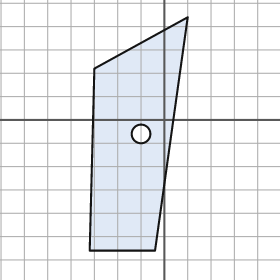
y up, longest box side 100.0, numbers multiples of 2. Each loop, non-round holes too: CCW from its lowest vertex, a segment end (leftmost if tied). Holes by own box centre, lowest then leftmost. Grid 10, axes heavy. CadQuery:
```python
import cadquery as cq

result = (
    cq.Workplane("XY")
    .moveTo(-32.0, -56.0)
    .lineTo(-4.0, -56.0)
    .lineTo(10.0, 44.0)
    .lineTo(-30.0, 22.0)
    .close()
    .moveTo(-10.0, -6.0)
    .circle(4.0)
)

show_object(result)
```